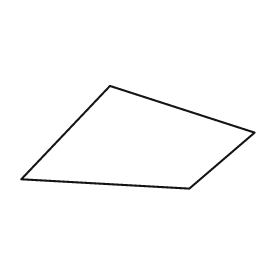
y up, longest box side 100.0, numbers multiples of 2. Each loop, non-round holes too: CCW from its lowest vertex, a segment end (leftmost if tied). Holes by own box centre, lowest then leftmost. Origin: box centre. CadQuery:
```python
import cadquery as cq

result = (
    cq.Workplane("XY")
    .moveTo(22.0, -22.0)
    .lineTo(50.0, 2.0)
    .lineTo(-12.0, 22.0)
    .lineTo(-50.0, -18.0)
    .close()
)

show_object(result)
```